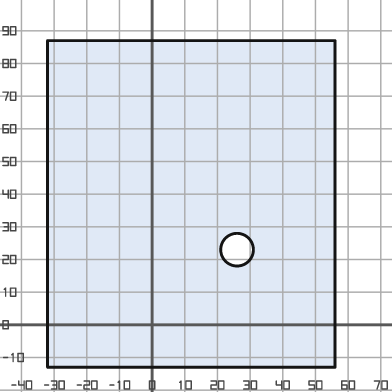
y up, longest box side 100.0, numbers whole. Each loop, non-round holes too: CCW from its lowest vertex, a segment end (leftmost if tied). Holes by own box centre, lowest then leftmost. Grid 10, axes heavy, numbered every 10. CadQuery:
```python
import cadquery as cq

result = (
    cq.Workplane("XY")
    .moveTo(-32.0, -13.0)
    .lineTo(56.0, -13.0)
    .lineTo(56.0, 87.0)
    .lineTo(-32.0, 87.0)
    .close()
    .moveTo(26.0, 23.0)
    .circle(5.0)
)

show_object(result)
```